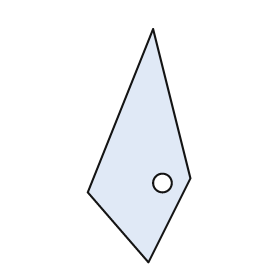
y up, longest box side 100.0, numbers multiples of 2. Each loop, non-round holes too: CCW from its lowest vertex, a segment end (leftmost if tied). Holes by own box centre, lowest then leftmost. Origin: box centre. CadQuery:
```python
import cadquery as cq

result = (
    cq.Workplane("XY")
    .moveTo(4.0, -50.0)
    .lineTo(22.0, -14.0)
    .lineTo(6.0, 50.0)
    .lineTo(-22.0, -20.0)
    .close()
    .moveTo(10.0, -16.0)
    .circle(4.0)
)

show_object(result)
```